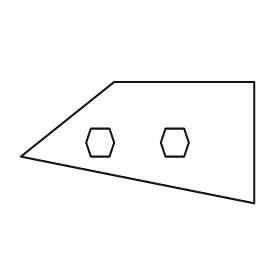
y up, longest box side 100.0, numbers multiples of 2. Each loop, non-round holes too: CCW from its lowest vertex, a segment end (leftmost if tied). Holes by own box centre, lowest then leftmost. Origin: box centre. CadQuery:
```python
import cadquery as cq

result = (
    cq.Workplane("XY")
    .moveTo(50.0, -26.0)
    .lineTo(50.0, 26.0)
    .lineTo(-10.0, 26.0)
    .lineTo(-50.0, -6.0)
    .close()
    .moveTo(-20.0, -6.0)
    .lineTo(-12.0, -6.0)
    .lineTo(-10.0, 0.0)
    .lineTo(-12.0, 6.0)
    .lineTo(-20.0, 6.0)
    .lineTo(-22.0, 0.0)
    .close()
    .moveTo(12.0, -6.0)
    .lineTo(20.0, -6.0)
    .lineTo(22.0, 0.0)
    .lineTo(20.0, 6.0)
    .lineTo(12.0, 6.0)
    .lineTo(10.0, 0.0)
    .close()
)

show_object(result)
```